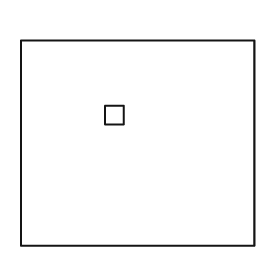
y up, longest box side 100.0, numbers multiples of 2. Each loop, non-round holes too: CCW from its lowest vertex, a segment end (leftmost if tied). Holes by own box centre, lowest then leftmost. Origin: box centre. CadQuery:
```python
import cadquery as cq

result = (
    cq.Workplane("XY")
    .moveTo(-50.0, -44.0)
    .lineTo(50.0, -44.0)
    .lineTo(50.0, 44.0)
    .lineTo(-50.0, 44.0)
    .close()
    .moveTo(-14.0, 8.0)
    .lineTo(-6.0, 8.0)
    .lineTo(-6.0, 16.0)
    .lineTo(-14.0, 16.0)
    .close()
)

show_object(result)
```